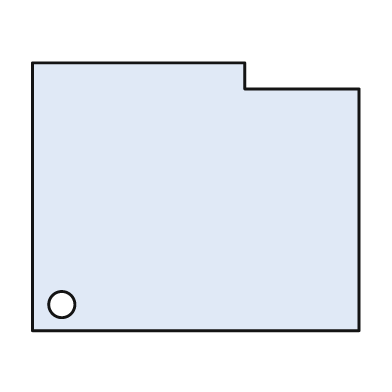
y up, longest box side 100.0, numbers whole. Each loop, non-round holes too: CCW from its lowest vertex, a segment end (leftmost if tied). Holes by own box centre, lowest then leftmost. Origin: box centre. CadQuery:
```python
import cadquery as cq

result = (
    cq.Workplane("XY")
    .moveTo(-50.0, -41.0)
    .lineTo(50.0, -41.0)
    .lineTo(50.0, 33.0)
    .lineTo(15.0, 33.0)
    .lineTo(15.0, 41.0)
    .lineTo(-50.0, 41.0)
    .close()
    .moveTo(-41.0, -33.0)
    .circle(4.0)
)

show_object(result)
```